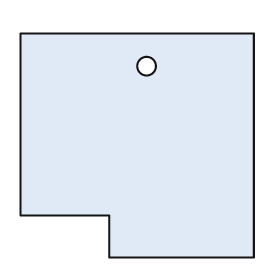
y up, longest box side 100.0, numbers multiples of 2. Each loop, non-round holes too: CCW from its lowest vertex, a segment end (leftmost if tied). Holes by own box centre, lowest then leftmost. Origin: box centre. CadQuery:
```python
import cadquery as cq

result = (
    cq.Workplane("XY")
    .moveTo(-12.0, -48.0)
    .lineTo(50.0, -48.0)
    .lineTo(50.0, 48.0)
    .lineTo(-50.0, 48.0)
    .lineTo(-50.0, -30.0)
    .lineTo(-12.0, -30.0)
    .close()
    .moveTo(4.0, 34.0)
    .circle(4.0)
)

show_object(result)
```